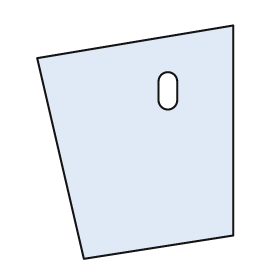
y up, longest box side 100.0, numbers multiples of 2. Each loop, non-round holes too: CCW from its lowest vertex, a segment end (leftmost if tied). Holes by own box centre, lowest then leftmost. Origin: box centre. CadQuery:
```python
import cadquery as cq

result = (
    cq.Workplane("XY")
    .moveTo(-22.0, -50.0)
    .lineTo(42.0, -40.0)
    .lineTo(42.0, 50.0)
    .lineTo(-42.0, 36.0)
    .close()
    .moveTo(10.0, 18.0)
    .threePointArc((14.0, 14.0), (18.0, 18.0))
    .lineTo(18.0, 26.0)
    .threePointArc((14.0, 30.0), (10.0, 26.0))
    .close()
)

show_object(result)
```